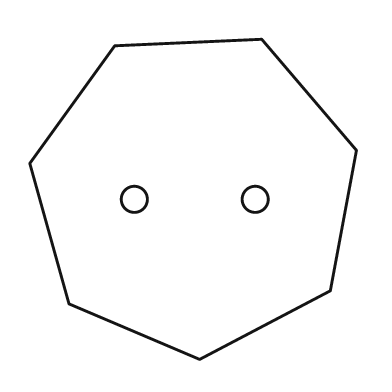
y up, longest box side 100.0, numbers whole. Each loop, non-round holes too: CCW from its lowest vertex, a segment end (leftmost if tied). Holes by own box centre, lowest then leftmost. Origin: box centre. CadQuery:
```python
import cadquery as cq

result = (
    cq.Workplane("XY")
    .moveTo(2.0, -49.0)
    .lineTo(42.0, -28.0)
    .lineTo(50.0, 15.0)
    .lineTo(21.0, 49.0)
    .lineTo(-24.0, 47.0)
    .lineTo(-50.0, 11.0)
    .lineTo(-38.0, -32.0)
    .close()
    .moveTo(-18.0, 0.0)
    .circle(4.0)
    .moveTo(19.0, 0.0)
    .circle(4.0)
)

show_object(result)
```